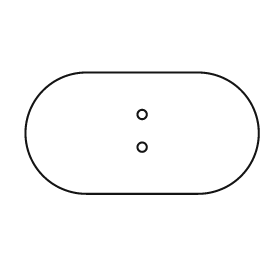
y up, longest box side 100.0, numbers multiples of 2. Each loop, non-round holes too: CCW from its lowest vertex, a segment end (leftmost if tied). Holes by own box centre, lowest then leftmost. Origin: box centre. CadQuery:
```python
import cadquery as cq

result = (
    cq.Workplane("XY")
    .moveTo(-24.0, -26.0)
    .lineTo(24.0, -26.0)
    .threePointArc((50.0, 0.0), (24.0, 26.0))
    .lineTo(-24.0, 26.0)
    .threePointArc((-50.0, 0.0), (-24.0, -26.0))
    .close()
    .moveTo(0.0, -6.0)
    .circle(2.0)
    .moveTo(0.0, 8.0)
    .circle(2.0)
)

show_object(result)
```